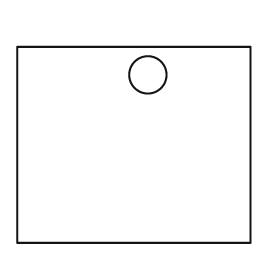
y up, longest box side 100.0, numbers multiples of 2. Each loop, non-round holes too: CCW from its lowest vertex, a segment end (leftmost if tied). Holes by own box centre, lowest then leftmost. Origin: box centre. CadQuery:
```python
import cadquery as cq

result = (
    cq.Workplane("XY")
    .moveTo(-50.0, -42.0)
    .lineTo(50.0, -42.0)
    .lineTo(50.0, 42.0)
    .lineTo(-50.0, 42.0)
    .close()
    .moveTo(6.0, 30.0)
    .circle(8.0)
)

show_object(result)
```